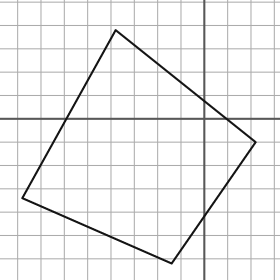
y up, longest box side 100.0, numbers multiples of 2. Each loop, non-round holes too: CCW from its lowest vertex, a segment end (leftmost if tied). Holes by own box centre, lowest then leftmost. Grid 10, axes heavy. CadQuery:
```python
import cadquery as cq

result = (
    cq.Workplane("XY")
    .moveTo(-14.0, -62.0)
    .lineTo(22.0, -10.0)
    .lineTo(-38.0, 38.0)
    .lineTo(-78.0, -34.0)
    .close()
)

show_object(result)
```